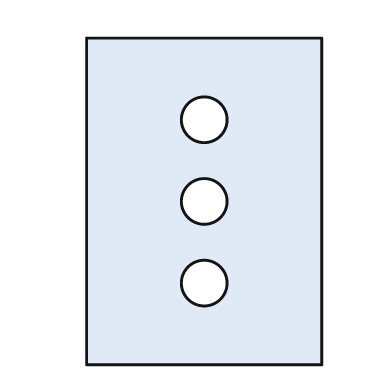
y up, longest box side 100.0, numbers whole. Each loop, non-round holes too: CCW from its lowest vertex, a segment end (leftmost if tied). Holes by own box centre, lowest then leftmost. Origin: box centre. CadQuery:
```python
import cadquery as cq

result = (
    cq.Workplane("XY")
    .moveTo(-36.0, -50.0)
    .lineTo(36.0, -50.0)
    .lineTo(36.0, 50.0)
    .lineTo(-36.0, 50.0)
    .close()
    .moveTo(0.0, -25.0)
    .circle(7.0)
    .moveTo(0.0, 0.0)
    .circle(7.0)
    .moveTo(0.0, 25.0)
    .circle(7.0)
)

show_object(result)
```